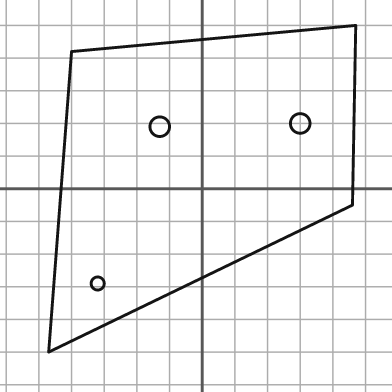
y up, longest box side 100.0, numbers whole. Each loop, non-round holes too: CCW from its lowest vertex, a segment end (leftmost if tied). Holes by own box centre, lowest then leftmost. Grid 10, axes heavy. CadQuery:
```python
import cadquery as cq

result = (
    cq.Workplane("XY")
    .moveTo(-47.0, -50.0)
    .lineTo(46.0, -5.0)
    .lineTo(47.0, 50.0)
    .lineTo(-40.0, 42.0)
    .close()
    .moveTo(-32.0, -29.0)
    .circle(2.0)
    .moveTo(-13.0, 19.0)
    .circle(3.0)
    .moveTo(30.0, 20.0)
    .circle(3.0)
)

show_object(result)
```